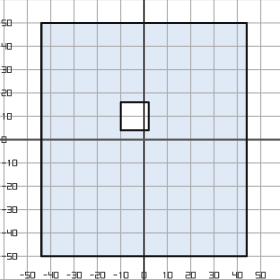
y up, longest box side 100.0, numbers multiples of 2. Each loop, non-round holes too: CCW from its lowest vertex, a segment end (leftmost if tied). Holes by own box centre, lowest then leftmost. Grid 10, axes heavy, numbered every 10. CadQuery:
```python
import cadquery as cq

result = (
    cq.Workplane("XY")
    .moveTo(-44.0, -50.0)
    .lineTo(44.0, -50.0)
    .lineTo(44.0, 50.0)
    .lineTo(-44.0, 50.0)
    .close()
    .moveTo(-10.0, 4.0)
    .lineTo(2.0, 4.0)
    .lineTo(2.0, 16.0)
    .lineTo(-10.0, 16.0)
    .close()
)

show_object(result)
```